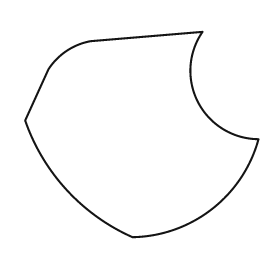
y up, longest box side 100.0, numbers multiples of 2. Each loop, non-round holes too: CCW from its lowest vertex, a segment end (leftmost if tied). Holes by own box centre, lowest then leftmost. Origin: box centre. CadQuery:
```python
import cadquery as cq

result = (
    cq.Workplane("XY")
    .moveTo(-4.0, -44.0)
    .threePointArc((30.0, -32.0), (50.0, -2.0))
    .threePointArc((24.0, 14.0), (26.0, 44.0))
    .lineTo(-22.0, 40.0)
    .threePointArc((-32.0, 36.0), (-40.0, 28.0))
    .lineTo(-50.0, 6.0)
    .threePointArc((-32.0, -24.0), (-4.0, -44.0))
    .close()
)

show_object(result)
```